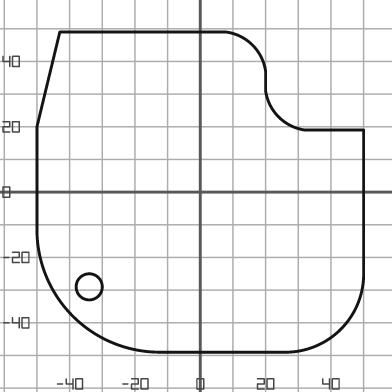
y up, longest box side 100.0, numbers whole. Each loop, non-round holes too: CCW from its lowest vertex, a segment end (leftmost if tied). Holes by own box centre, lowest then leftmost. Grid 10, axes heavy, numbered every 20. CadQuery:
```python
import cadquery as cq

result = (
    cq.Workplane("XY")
    .moveTo(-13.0, -49.0)
    .lineTo(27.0, -49.0)
    .threePointArc((43.0, -42.0), (50.0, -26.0))
    .lineTo(50.0, 19.0)
    .lineTo(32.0, 19.0)
    .threePointArc((24.0, 23.0), (20.0, 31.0))
    .lineTo(20.0, 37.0)
    .threePointArc((16.0, 45.0), (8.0, 49.0))
    .lineTo(-43.0, 49.0)
    .lineTo(-50.0, 20.0)
    .lineTo(-50.0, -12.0)
    .threePointArc((-39.0, -38.0), (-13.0, -49.0))
    .close()
    .moveTo(-34.0, -29.0)
    .circle(4.0)
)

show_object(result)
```